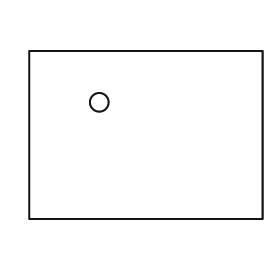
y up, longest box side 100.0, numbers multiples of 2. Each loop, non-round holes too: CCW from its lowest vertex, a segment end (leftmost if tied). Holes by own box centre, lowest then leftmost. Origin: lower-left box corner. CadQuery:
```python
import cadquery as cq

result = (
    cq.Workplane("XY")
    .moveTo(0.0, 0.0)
    .lineTo(100.0, 0.0)
    .lineTo(100.0, 72.0)
    .lineTo(0.0, 72.0)
    .close()
    .moveTo(30.0, 50.0)
    .circle(4.0)
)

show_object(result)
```